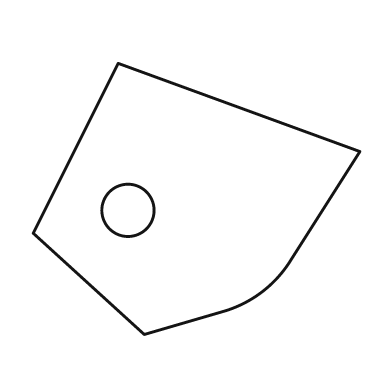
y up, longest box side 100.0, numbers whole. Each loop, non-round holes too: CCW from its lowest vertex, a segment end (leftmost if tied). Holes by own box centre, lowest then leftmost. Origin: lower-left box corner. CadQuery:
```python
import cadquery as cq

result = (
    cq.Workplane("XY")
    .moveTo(34.0, 0.0)
    .lineTo(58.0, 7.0)
    .threePointArc((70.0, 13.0), (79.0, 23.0))
    .lineTo(100.0, 56.0)
    .lineTo(26.0, 83.0)
    .lineTo(0.0, 31.0)
    .close()
    .moveTo(29.0, 38.0)
    .circle(8.0)
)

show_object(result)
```